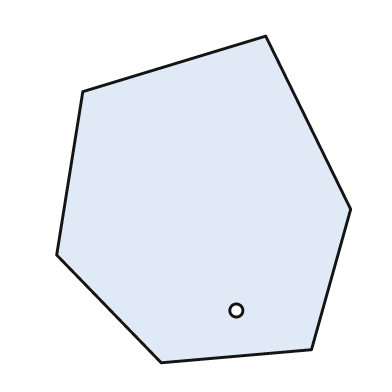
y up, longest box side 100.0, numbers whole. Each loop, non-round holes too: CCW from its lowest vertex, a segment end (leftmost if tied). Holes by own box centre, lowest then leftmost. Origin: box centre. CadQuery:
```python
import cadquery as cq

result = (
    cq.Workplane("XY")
    .moveTo(-13.0, -50.0)
    .lineTo(33.0, -46.0)
    .lineTo(45.0, -3.0)
    .lineTo(19.0, 50.0)
    .lineTo(-37.0, 33.0)
    .lineTo(-45.0, -17.0)
    .close()
    .moveTo(10.0, -34.0)
    .circle(2.0)
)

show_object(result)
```